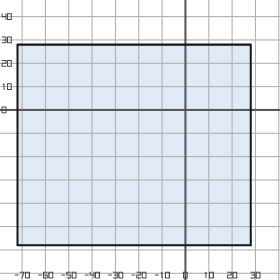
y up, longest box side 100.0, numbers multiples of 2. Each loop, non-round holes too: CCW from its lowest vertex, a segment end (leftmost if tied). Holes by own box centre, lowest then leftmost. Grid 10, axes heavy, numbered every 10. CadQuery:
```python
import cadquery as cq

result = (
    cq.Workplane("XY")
    .moveTo(-72.0, -58.0)
    .lineTo(28.0, -58.0)
    .lineTo(28.0, 28.0)
    .lineTo(-72.0, 28.0)
    .close()
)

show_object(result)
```